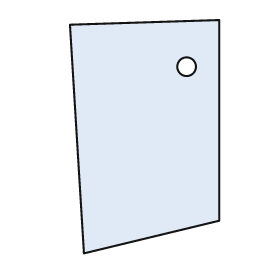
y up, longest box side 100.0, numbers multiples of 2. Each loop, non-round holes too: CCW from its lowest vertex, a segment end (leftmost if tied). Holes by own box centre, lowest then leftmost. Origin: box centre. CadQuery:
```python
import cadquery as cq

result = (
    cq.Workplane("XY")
    .moveTo(-26.0, -50.0)
    .lineTo(32.0, -36.0)
    .lineTo(32.0, 50.0)
    .lineTo(-32.0, 48.0)
    .close()
    .moveTo(18.0, 30.0)
    .circle(4.0)
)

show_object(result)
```